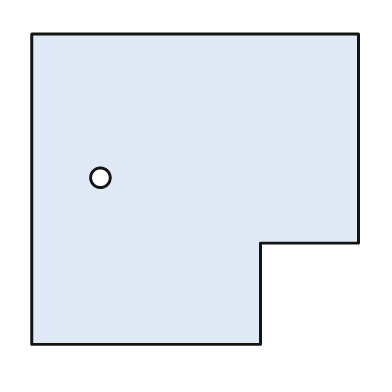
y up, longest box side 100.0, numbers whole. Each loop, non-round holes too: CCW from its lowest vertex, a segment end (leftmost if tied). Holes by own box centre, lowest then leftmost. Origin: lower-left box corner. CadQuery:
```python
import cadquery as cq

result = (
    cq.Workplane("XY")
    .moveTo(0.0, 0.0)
    .lineTo(70.0, 0.0)
    .lineTo(70.0, 31.0)
    .lineTo(100.0, 31.0)
    .lineTo(100.0, 95.0)
    .lineTo(0.0, 95.0)
    .close()
    .moveTo(21.0, 51.0)
    .circle(3.0)
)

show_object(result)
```